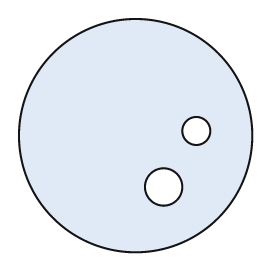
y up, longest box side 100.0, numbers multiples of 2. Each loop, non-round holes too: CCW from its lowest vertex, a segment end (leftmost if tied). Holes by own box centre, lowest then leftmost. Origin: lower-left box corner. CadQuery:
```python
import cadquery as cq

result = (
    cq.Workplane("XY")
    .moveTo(50.0, 50.0)
    .circle(50.0)
    .moveTo(62.0, 28.0)
    .circle(8.0)
    .moveTo(76.0, 52.0)
    .circle(6.0)
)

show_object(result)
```